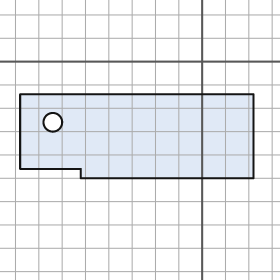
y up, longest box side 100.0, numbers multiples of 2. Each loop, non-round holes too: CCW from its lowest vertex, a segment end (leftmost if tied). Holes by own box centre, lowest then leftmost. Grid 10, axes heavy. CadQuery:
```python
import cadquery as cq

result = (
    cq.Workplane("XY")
    .moveTo(-52.0, -50.0)
    .lineTo(22.0, -50.0)
    .lineTo(22.0, -14.0)
    .lineTo(-78.0, -14.0)
    .lineTo(-78.0, -46.0)
    .lineTo(-52.0, -46.0)
    .close()
    .moveTo(-64.0, -26.0)
    .circle(4.0)
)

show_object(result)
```